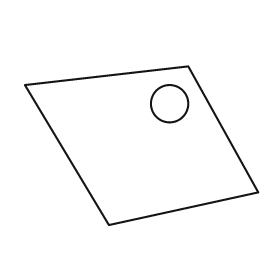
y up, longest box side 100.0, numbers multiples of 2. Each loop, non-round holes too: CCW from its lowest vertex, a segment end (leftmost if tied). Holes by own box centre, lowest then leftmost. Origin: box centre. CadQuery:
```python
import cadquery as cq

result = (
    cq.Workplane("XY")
    .moveTo(-14.0, -34.0)
    .lineTo(50.0, -20.0)
    .lineTo(20.0, 34.0)
    .lineTo(-50.0, 26.0)
    .close()
    .moveTo(12.0, 18.0)
    .circle(8.0)
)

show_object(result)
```